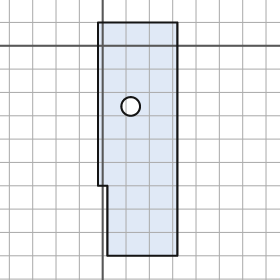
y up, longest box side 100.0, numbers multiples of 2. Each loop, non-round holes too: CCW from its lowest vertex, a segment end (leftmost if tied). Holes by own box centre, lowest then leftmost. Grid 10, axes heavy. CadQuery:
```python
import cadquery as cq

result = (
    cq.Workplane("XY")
    .moveTo(2.0, -90.0)
    .lineTo(32.0, -90.0)
    .lineTo(32.0, 10.0)
    .lineTo(-2.0, 10.0)
    .lineTo(-2.0, -60.0)
    .lineTo(2.0, -60.0)
    .close()
    .moveTo(12.0, -26.0)
    .circle(4.0)
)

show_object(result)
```